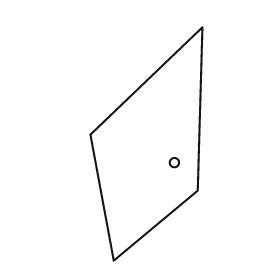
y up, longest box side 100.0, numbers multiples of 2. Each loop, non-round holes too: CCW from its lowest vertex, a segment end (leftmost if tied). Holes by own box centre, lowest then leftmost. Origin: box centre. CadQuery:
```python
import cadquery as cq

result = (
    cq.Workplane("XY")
    .moveTo(-14.0, -50.0)
    .lineTo(22.0, -20.0)
    .lineTo(24.0, 50.0)
    .lineTo(-24.0, 4.0)
    .close()
    .moveTo(12.0, -8.0)
    .circle(2.0)
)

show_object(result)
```